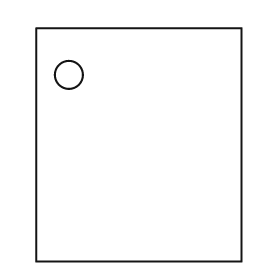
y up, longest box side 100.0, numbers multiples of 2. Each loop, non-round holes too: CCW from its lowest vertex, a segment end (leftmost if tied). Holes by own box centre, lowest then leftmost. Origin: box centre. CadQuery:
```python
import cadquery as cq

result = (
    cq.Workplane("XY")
    .moveTo(-44.0, -50.0)
    .lineTo(44.0, -50.0)
    .lineTo(44.0, 50.0)
    .lineTo(-44.0, 50.0)
    .close()
    .moveTo(-30.0, 30.0)
    .circle(6.0)
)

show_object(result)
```